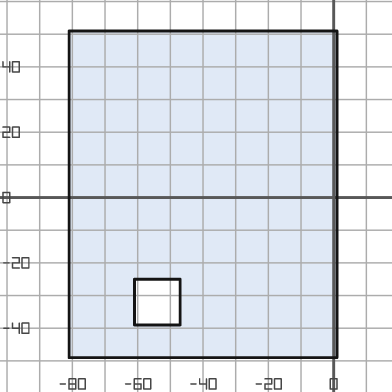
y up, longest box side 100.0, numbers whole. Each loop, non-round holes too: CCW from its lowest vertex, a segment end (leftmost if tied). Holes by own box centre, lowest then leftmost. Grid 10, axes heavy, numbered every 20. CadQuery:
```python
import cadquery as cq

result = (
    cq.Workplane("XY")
    .moveTo(-81.0, -49.0)
    .lineTo(1.0, -49.0)
    .lineTo(1.0, 51.0)
    .lineTo(-81.0, 51.0)
    .close()
    .moveTo(-61.0, -39.0)
    .lineTo(-47.0, -39.0)
    .lineTo(-47.0, -25.0)
    .lineTo(-61.0, -25.0)
    .close()
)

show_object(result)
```